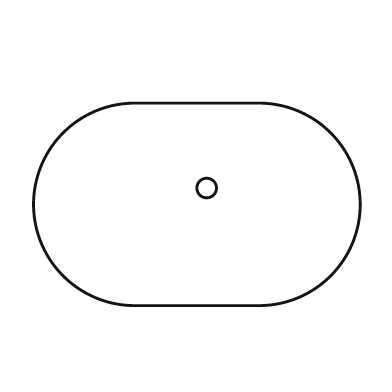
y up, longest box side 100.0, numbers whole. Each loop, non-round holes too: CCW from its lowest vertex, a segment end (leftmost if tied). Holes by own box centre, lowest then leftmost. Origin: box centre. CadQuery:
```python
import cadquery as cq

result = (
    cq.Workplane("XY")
    .moveTo(-19.0, -31.0)
    .lineTo(19.0, -31.0)
    .threePointArc((50.0, 0.0), (19.0, 31.0))
    .lineTo(-19.0, 31.0)
    .threePointArc((-50.0, 0.0), (-19.0, -31.0))
    .close()
    .moveTo(3.0, 5.0)
    .circle(3.0)
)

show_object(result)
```